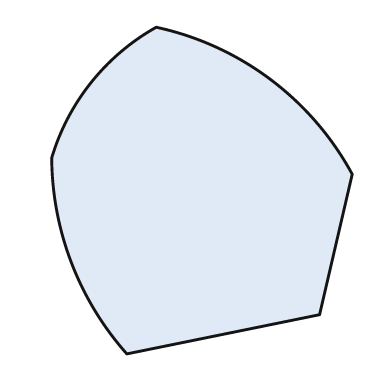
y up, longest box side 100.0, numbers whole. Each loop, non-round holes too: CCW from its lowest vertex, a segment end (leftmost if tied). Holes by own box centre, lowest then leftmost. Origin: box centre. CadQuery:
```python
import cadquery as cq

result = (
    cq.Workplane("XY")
    .moveTo(-23.0, -50.0)
    .lineTo(36.0, -38.0)
    .lineTo(46.0, 5.0)
    .threePointArc((21.0, 34.0), (-14.0, 50.0))
    .threePointArc((-34.0, 33.0), (-46.0, 10.0))
    .threePointArc((-40.0, -22.0), (-23.0, -50.0))
    .close()
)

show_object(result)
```